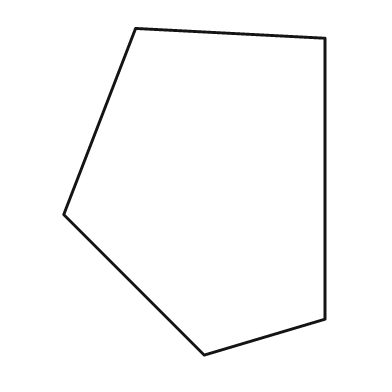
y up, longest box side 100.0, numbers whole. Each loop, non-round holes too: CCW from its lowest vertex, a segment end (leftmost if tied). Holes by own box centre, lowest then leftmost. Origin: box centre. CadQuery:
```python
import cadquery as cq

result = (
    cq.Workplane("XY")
    .moveTo(3.0, -50.0)
    .lineTo(40.0, -39.0)
    .lineTo(40.0, 47.0)
    .lineTo(-18.0, 50.0)
    .lineTo(-40.0, -7.0)
    .close()
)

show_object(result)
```